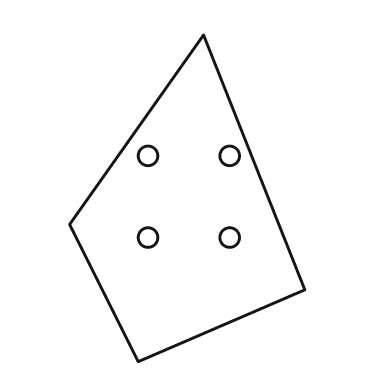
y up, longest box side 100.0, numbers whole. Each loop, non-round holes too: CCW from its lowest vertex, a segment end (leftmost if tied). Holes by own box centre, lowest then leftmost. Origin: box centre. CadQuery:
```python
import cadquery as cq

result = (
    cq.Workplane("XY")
    .moveTo(-15.0, -50.0)
    .lineTo(36.0, -28.0)
    .lineTo(5.0, 50.0)
    .lineTo(-36.0, -8.0)
    .close()
    .moveTo(-12.0, -12.0)
    .circle(3.0)
    .moveTo(13.0, -12.0)
    .circle(3.0)
    .moveTo(-12.0, 13.0)
    .circle(3.0)
    .moveTo(13.0, 13.0)
    .circle(3.0)
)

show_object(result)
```